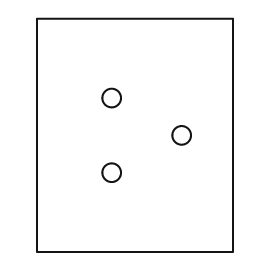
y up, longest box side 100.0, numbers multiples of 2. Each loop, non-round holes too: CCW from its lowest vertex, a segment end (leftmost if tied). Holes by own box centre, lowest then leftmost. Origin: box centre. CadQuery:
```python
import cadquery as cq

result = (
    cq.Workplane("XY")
    .moveTo(-42.0, -50.0)
    .lineTo(42.0, -50.0)
    .lineTo(42.0, 50.0)
    .lineTo(-42.0, 50.0)
    .close()
    .moveTo(-10.0, -16.0)
    .circle(4.0)
    .moveTo(20.0, 0.0)
    .circle(4.0)
    .moveTo(-10.0, 16.0)
    .circle(4.0)
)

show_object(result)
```